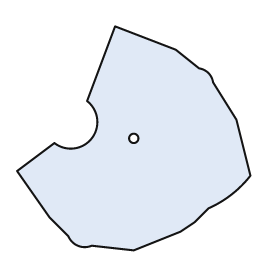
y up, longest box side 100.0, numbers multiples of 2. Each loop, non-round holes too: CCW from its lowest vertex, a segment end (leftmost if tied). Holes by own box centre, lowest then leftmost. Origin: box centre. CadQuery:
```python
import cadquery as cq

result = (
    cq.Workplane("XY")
    .moveTo(0.0, -48.0)
    .lineTo(20.0, -40.0)
    .lineTo(26.0, -36.0)
    .lineTo(32.0, -30.0)
    .threePointArc((42.0, -24.0), (50.0, -16.0))
    .lineTo(44.0, 8.0)
    .lineTo(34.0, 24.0)
    .threePointArc((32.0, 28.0), (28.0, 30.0))
    .lineTo(18.0, 38.0)
    .lineTo(-8.0, 48.0)
    .lineTo(-20.0, 16.0)
    .threePointArc((-18.0, 0.0), (-34.0, -2.0))
    .lineTo(-50.0, -14.0)
    .lineTo(-36.0, -34.0)
    .lineTo(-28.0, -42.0)
    .threePointArc((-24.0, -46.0), (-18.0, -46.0))
    .close()
    .moveTo(0.0, 0.0)
    .circle(2.0)
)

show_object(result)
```